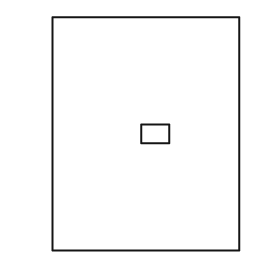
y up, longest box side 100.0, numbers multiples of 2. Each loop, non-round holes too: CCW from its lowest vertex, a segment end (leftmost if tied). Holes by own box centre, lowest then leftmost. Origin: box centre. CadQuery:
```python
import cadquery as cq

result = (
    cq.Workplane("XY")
    .moveTo(-40.0, -50.0)
    .lineTo(40.0, -50.0)
    .lineTo(40.0, 50.0)
    .lineTo(-40.0, 50.0)
    .close()
    .moveTo(-2.0, -4.0)
    .lineTo(10.0, -4.0)
    .lineTo(10.0, 4.0)
    .lineTo(-2.0, 4.0)
    .close()
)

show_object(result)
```